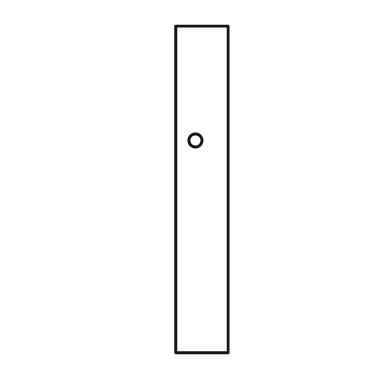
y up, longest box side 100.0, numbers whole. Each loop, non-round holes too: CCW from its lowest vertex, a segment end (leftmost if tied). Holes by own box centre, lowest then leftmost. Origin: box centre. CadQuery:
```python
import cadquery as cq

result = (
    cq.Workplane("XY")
    .moveTo(-8.0, -50.0)
    .lineTo(8.0, -50.0)
    .lineTo(8.0, 50.0)
    .lineTo(-8.0, 50.0)
    .close()
    .moveTo(-2.0, 15.0)
    .circle(2.0)
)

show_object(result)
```